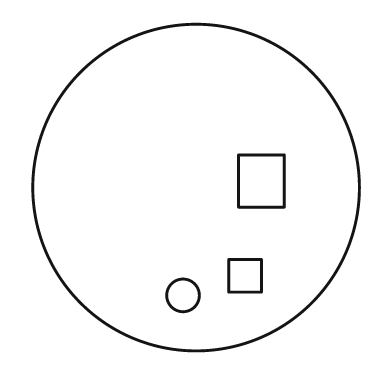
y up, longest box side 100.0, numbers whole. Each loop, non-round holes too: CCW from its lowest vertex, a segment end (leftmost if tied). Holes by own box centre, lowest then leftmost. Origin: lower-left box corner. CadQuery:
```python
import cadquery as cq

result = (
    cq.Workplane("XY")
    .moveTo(50.0, 50.0)
    .circle(50.0)
    .moveTo(46.0, 17.0)
    .circle(5.0)
    .moveTo(60.0, 18.0)
    .lineTo(70.0, 18.0)
    .lineTo(70.0, 28.0)
    .lineTo(60.0, 28.0)
    .close()
    .moveTo(63.0, 44.0)
    .lineTo(77.0, 44.0)
    .lineTo(77.0, 60.0)
    .lineTo(63.0, 60.0)
    .close()
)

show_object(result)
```